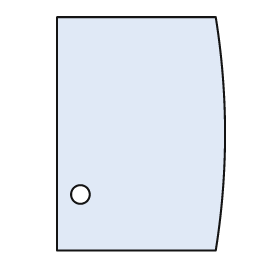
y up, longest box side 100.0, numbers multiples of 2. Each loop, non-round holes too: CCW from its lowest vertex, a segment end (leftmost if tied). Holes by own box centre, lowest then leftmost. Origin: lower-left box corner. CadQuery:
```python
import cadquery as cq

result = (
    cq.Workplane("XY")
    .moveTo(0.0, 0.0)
    .lineTo(68.0, 0.0)
    .threePointArc((72.0, 50.0), (68.0, 100.0))
    .lineTo(0.0, 100.0)
    .close()
    .moveTo(10.0, 24.0)
    .circle(4.0)
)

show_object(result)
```